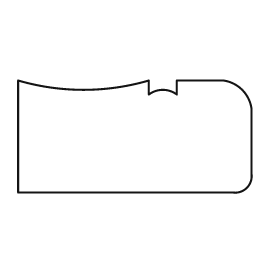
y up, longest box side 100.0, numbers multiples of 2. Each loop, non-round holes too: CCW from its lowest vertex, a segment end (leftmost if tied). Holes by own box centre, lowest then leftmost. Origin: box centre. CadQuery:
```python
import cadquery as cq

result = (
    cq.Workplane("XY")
    .moveTo(-50.0, -24.0)
    .lineTo(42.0, -24.0)
    .threePointArc((48.0, -22.0), (50.0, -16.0))
    .lineTo(50.0, 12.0)
    .threePointArc((46.0, 20.0), (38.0, 24.0))
    .lineTo(18.0, 24.0)
    .lineTo(18.0, 18.0)
    .threePointArc((12.0, 20.0), (6.0, 18.0))
    .lineTo(6.0, 24.0)
    .threePointArc((-22.0, 20.0), (-50.0, 24.0))
    .close()
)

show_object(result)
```